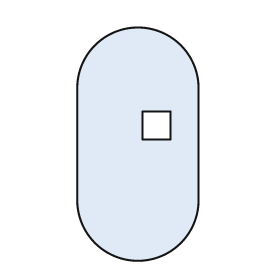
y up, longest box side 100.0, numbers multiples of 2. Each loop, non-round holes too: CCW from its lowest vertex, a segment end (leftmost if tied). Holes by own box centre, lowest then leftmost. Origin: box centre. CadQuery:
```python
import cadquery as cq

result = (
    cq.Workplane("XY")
    .moveTo(-26.0, -24.0)
    .threePointArc((0.0, -50.0), (26.0, -24.0))
    .lineTo(26.0, 24.0)
    .threePointArc((0.0, 50.0), (-26.0, 24.0))
    .close()
    .moveTo(2.0, 2.0)
    .lineTo(14.0, 2.0)
    .lineTo(14.0, 14.0)
    .lineTo(2.0, 14.0)
    .close()
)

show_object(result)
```